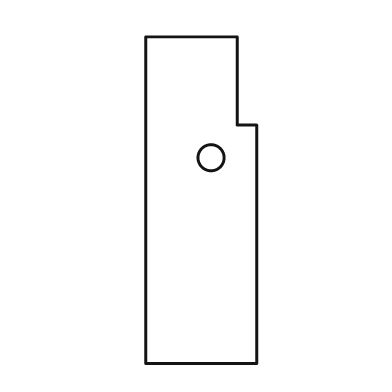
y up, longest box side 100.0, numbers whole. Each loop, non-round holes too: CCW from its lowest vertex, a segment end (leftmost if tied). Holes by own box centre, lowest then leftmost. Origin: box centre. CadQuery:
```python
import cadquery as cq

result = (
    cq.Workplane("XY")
    .moveTo(-17.0, -50.0)
    .lineTo(17.0, -50.0)
    .lineTo(17.0, 23.0)
    .lineTo(11.0, 23.0)
    .lineTo(11.0, 50.0)
    .lineTo(-17.0, 50.0)
    .close()
    .moveTo(3.0, 13.0)
    .circle(4.0)
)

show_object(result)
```